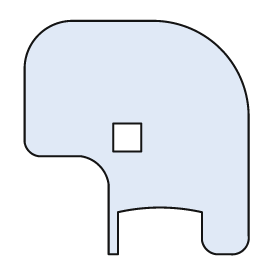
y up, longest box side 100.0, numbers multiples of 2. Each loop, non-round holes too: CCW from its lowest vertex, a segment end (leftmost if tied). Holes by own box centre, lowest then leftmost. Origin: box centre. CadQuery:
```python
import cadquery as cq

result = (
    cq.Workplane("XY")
    .moveTo(-12.0, -50.0)
    .lineTo(-8.0, -50.0)
    .lineTo(-8.0, -32.0)
    .threePointArc((10.0, -30.0), (28.0, -32.0))
    .lineTo(28.0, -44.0)
    .threePointArc((30.0, -48.0), (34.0, -50.0))
    .lineTo(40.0, -50.0)
    .threePointArc((46.0, -48.0), (48.0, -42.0))
    .lineTo(48.0, 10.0)
    .threePointArc((36.0, 38.0), (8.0, 50.0))
    .lineTo(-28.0, 50.0)
    .threePointArc((-42.0, 44.0), (-48.0, 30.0))
    .lineTo(-48.0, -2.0)
    .threePointArc((-46.0, -6.0), (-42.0, -8.0))
    .lineTo(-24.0, -8.0)
    .threePointArc((-16.0, -12.0), (-12.0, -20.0))
    .close()
    .moveTo(-10.0, -6.0)
    .lineTo(2.0, -6.0)
    .lineTo(2.0, 6.0)
    .lineTo(-10.0, 6.0)
    .close()
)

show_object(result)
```